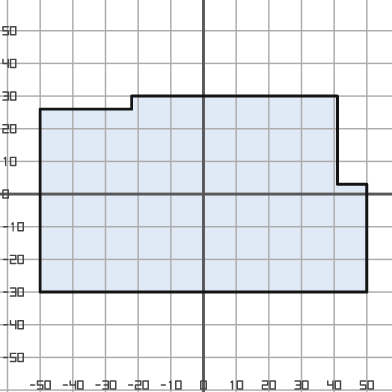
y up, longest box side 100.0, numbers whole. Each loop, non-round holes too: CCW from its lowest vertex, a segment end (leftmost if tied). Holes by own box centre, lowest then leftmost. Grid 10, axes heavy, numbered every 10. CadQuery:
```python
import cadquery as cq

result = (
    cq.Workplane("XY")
    .moveTo(-50.0, -30.0)
    .lineTo(50.0, -30.0)
    .lineTo(50.0, 3.0)
    .lineTo(41.0, 3.0)
    .lineTo(41.0, 30.0)
    .lineTo(-22.0, 30.0)
    .lineTo(-22.0, 26.0)
    .lineTo(-50.0, 26.0)
    .close()
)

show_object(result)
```